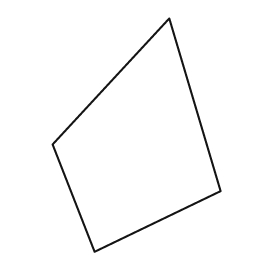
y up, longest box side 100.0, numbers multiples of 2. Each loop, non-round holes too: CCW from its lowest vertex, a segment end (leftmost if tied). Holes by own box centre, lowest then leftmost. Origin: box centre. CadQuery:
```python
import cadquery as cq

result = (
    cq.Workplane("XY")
    .moveTo(-18.0, -50.0)
    .lineTo(36.0, -24.0)
    .lineTo(14.0, 50.0)
    .lineTo(-36.0, -4.0)
    .close()
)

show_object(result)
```